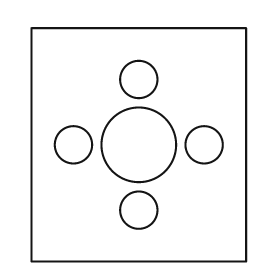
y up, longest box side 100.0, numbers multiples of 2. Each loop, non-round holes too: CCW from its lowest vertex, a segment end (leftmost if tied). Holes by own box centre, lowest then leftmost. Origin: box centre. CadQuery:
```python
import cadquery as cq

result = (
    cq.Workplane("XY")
    .moveTo(-46.0, -50.0)
    .lineTo(46.0, -50.0)
    .lineTo(46.0, 50.0)
    .lineTo(-46.0, 50.0)
    .close()
    .moveTo(0.0, -28.0)
    .circle(8.0)
    .moveTo(-28.0, 0.0)
    .circle(8.0)
    .moveTo(0.0, 0.0)
    .circle(16.0)
    .moveTo(28.0, 0.0)
    .circle(8.0)
    .moveTo(0.0, 28.0)
    .circle(8.0)
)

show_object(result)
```